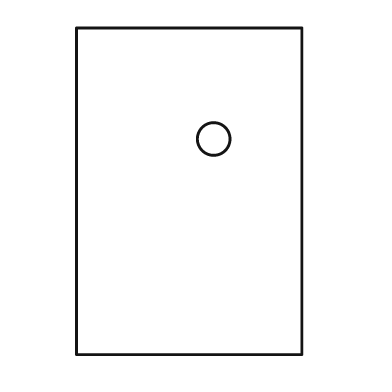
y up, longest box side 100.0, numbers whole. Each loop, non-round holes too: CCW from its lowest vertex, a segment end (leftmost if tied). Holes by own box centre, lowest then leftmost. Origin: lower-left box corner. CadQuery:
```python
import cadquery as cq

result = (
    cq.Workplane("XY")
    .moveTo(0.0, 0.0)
    .lineTo(69.0, 0.0)
    .lineTo(69.0, 100.0)
    .lineTo(0.0, 100.0)
    .close()
    .moveTo(42.0, 66.0)
    .circle(5.0)
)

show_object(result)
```